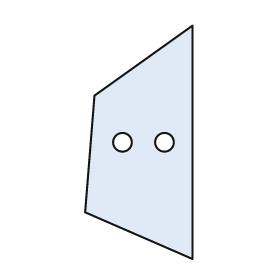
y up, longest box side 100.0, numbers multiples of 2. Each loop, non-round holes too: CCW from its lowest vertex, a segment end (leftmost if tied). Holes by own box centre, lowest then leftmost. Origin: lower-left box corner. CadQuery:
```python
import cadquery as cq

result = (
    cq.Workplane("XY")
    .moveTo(46.0, 0.0)
    .lineTo(46.0, 100.0)
    .lineTo(4.0, 70.0)
    .lineTo(0.0, 20.0)
    .close()
    .moveTo(16.0, 50.0)
    .circle(4.0)
    .moveTo(34.0, 50.0)
    .circle(4.0)
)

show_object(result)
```